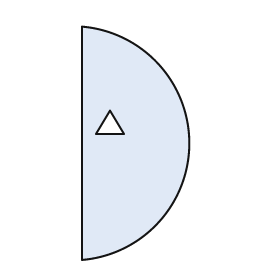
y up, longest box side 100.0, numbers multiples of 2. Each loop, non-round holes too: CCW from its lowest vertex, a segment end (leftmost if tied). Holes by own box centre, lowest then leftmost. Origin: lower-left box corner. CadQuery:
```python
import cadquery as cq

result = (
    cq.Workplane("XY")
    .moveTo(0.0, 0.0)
    .threePointArc((46.0, 50.0), (0.0, 100.0))
    .close()
    .moveTo(6.0, 54.0)
    .lineTo(18.0, 54.0)
    .lineTo(12.0, 64.0)
    .close()
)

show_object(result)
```